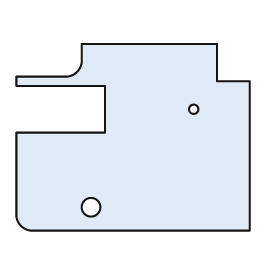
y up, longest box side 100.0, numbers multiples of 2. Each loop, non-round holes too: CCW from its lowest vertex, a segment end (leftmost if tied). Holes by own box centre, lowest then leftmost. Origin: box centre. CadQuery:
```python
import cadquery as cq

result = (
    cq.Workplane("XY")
    .moveTo(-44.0, -40.0)
    .lineTo(50.0, -40.0)
    .lineTo(50.0, 24.0)
    .lineTo(36.0, 24.0)
    .lineTo(36.0, 40.0)
    .lineTo(-22.0, 40.0)
    .lineTo(-22.0, 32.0)
    .threePointArc((-24.0, 28.0), (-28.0, 26.0))
    .lineTo(-50.0, 26.0)
    .lineTo(-50.0, 22.0)
    .lineTo(-12.0, 22.0)
    .lineTo(-12.0, 2.0)
    .lineTo(-50.0, 2.0)
    .lineTo(-50.0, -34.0)
    .threePointArc((-48.0, -38.0), (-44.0, -40.0))
    .close()
    .moveTo(-18.0, -30.0)
    .circle(4.0)
    .moveTo(26.0, 12.0)
    .circle(2.0)
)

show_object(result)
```